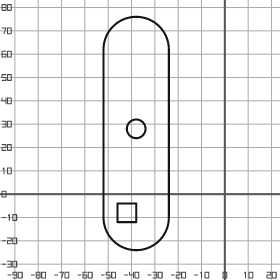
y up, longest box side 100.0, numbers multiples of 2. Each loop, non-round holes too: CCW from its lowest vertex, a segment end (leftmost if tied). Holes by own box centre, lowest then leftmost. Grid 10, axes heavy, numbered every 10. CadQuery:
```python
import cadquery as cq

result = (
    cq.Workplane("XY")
    .moveTo(-52.0, -10.0)
    .threePointArc((-38.0, -24.0), (-24.0, -10.0))
    .lineTo(-24.0, 62.0)
    .threePointArc((-38.0, 76.0), (-52.0, 62.0))
    .close()
    .moveTo(-46.0, -12.0)
    .lineTo(-38.0, -12.0)
    .lineTo(-38.0, -4.0)
    .lineTo(-46.0, -4.0)
    .close()
    .moveTo(-38.0, 28.0)
    .circle(4.0)
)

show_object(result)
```